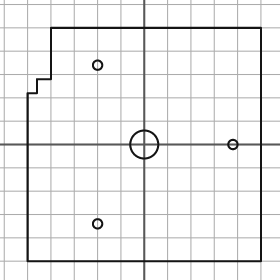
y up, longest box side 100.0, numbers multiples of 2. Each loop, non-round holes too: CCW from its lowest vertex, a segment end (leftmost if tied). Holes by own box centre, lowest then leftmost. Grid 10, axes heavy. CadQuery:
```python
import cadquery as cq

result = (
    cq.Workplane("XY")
    .moveTo(-50.0, -50.0)
    .lineTo(50.0, -50.0)
    .lineTo(50.0, 50.0)
    .lineTo(-40.0, 50.0)
    .lineTo(-40.0, 28.0)
    .lineTo(-46.0, 28.0)
    .lineTo(-46.0, 22.0)
    .lineTo(-50.0, 22.0)
    .close()
    .moveTo(-20.0, -34.0)
    .circle(2.0)
    .moveTo(0.0, 0.0)
    .circle(6.0)
    .moveTo(38.0, 0.0)
    .circle(2.0)
    .moveTo(-20.0, 34.0)
    .circle(2.0)
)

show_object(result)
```